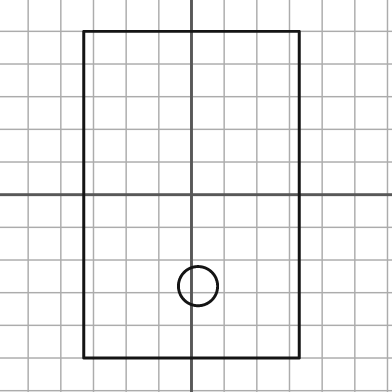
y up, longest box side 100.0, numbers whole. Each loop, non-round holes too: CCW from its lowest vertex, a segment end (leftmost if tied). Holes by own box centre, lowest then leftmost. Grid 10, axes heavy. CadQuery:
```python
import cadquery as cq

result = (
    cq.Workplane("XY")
    .moveTo(-33.0, -50.0)
    .lineTo(33.0, -50.0)
    .lineTo(33.0, 50.0)
    .lineTo(-33.0, 50.0)
    .close()
    .moveTo(2.0, -28.0)
    .circle(6.0)
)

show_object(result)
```